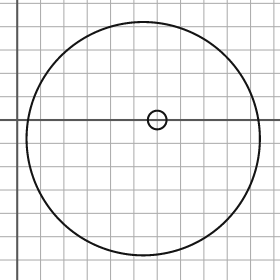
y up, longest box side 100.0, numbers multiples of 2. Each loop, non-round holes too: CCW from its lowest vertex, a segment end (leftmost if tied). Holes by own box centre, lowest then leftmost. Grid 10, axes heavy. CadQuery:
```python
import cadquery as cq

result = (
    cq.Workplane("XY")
    .moveTo(54.0, -8.0)
    .circle(50.0)
    .moveTo(60.0, 0.0)
    .circle(4.0)
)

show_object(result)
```